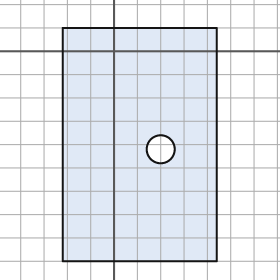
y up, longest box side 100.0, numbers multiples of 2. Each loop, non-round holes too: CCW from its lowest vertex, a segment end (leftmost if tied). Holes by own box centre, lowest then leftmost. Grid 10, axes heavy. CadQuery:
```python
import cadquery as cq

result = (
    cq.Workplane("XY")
    .moveTo(-22.0, -90.0)
    .lineTo(44.0, -90.0)
    .lineTo(44.0, 10.0)
    .lineTo(-22.0, 10.0)
    .close()
    .moveTo(20.0, -42.0)
    .circle(6.0)
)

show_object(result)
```